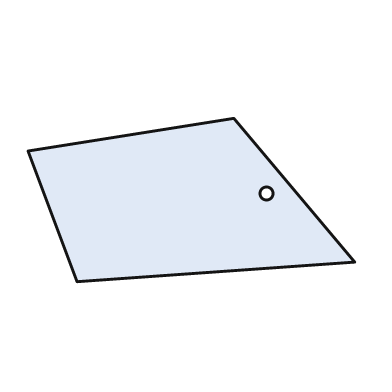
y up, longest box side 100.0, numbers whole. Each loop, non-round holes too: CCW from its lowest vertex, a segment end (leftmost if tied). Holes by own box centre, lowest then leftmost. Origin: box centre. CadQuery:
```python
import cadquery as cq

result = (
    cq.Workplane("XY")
    .moveTo(-35.0, -25.0)
    .lineTo(50.0, -19.0)
    .lineTo(13.0, 25.0)
    .lineTo(-50.0, 15.0)
    .close()
    .moveTo(23.0, 2.0)
    .circle(2.0)
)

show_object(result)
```